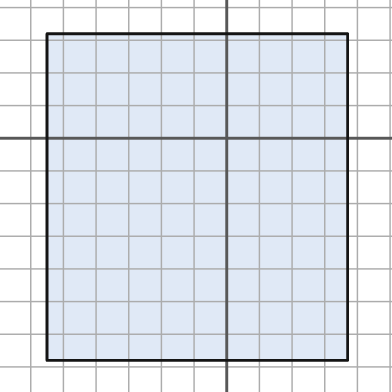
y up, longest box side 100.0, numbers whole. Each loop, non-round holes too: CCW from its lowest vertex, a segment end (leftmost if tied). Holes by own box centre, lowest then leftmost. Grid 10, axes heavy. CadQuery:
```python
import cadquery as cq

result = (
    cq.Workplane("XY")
    .moveTo(-55.0, -68.0)
    .lineTo(37.0, -68.0)
    .lineTo(37.0, 32.0)
    .lineTo(-55.0, 32.0)
    .close()
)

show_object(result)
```